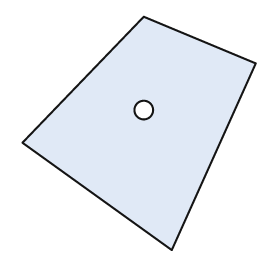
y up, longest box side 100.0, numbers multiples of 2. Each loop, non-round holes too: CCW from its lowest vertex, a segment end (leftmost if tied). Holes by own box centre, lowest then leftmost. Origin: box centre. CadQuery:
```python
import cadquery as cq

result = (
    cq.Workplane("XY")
    .moveTo(14.0, -50.0)
    .lineTo(50.0, 30.0)
    .lineTo(2.0, 50.0)
    .lineTo(-50.0, -4.0)
    .close()
    .moveTo(2.0, 10.0)
    .circle(4.0)
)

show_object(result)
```